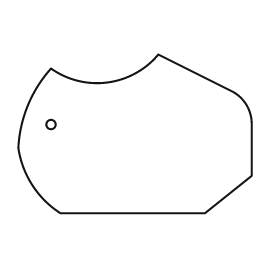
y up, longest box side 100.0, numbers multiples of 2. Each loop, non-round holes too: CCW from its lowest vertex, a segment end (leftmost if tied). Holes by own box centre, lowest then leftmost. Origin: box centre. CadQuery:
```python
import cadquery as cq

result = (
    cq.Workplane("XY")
    .moveTo(-32.0, -34.0)
    .lineTo(30.0, -34.0)
    .lineTo(50.0, -18.0)
    .lineTo(50.0, 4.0)
    .threePointArc((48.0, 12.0), (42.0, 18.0))
    .lineTo(10.0, 34.0)
    .threePointArc((-12.0, 22.0), (-36.0, 28.0))
    .threePointArc((-46.0, 12.0), (-50.0, -6.0))
    .threePointArc((-44.0, -22.0), (-32.0, -34.0))
    .close()
    .moveTo(-36.0, 4.0)
    .circle(2.0)
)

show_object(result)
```